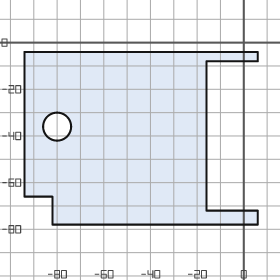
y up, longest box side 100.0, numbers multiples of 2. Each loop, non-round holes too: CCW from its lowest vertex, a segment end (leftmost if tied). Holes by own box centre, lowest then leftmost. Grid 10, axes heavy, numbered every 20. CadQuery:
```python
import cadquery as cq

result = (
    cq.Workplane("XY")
    .moveTo(-82.0, -78.0)
    .lineTo(6.0, -78.0)
    .lineTo(6.0, -72.0)
    .lineTo(-16.0, -72.0)
    .lineTo(-16.0, -8.0)
    .lineTo(6.0, -8.0)
    .lineTo(6.0, -4.0)
    .lineTo(-94.0, -4.0)
    .lineTo(-94.0, -66.0)
    .lineTo(-82.0, -66.0)
    .close()
    .moveTo(-80.0, -36.0)
    .circle(6.0)
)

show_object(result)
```